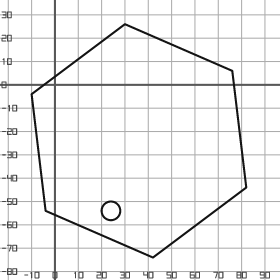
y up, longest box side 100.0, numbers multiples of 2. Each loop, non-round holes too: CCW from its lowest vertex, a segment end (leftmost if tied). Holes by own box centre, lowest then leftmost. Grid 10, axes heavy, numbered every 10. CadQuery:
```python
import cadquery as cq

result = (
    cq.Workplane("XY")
    .moveTo(42.0, -74.0)
    .lineTo(82.0, -44.0)
    .lineTo(76.0, 6.0)
    .lineTo(30.0, 26.0)
    .lineTo(-10.0, -4.0)
    .lineTo(-4.0, -54.0)
    .close()
    .moveTo(24.0, -54.0)
    .circle(4.0)
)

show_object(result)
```